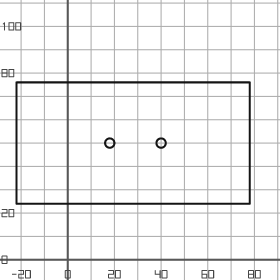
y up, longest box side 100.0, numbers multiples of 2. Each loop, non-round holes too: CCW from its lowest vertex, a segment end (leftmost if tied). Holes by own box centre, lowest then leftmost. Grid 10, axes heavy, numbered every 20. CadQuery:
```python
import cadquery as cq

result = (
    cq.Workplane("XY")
    .moveTo(-22.0, 24.0)
    .lineTo(78.0, 24.0)
    .lineTo(78.0, 76.0)
    .lineTo(-22.0, 76.0)
    .close()
    .moveTo(18.0, 50.0)
    .circle(2.0)
    .moveTo(40.0, 50.0)
    .circle(2.0)
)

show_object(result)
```